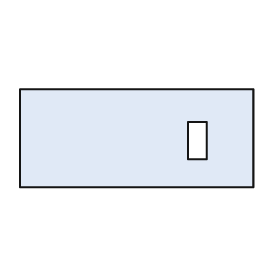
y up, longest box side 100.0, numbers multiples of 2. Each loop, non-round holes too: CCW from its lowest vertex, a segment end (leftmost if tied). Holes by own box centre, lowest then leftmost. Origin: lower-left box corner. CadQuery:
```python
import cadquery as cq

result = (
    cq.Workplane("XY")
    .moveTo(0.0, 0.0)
    .lineTo(100.0, 0.0)
    .lineTo(100.0, 42.0)
    .lineTo(0.0, 42.0)
    .close()
    .moveTo(72.0, 12.0)
    .lineTo(80.0, 12.0)
    .lineTo(80.0, 28.0)
    .lineTo(72.0, 28.0)
    .close()
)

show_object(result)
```